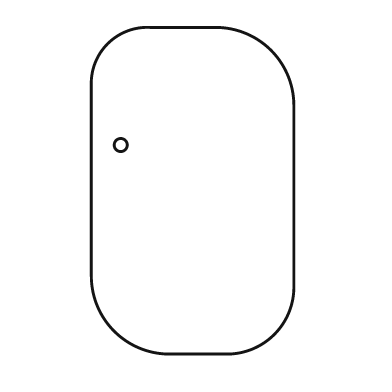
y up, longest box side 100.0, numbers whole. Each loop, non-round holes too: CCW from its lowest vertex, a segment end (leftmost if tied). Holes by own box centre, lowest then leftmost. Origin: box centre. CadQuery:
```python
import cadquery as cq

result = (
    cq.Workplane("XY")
    .moveTo(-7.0, -50.0)
    .lineTo(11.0, -50.0)
    .threePointArc((25.0, -44.0), (31.0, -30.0))
    .lineTo(31.0, 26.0)
    .threePointArc((24.0, 43.0), (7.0, 50.0))
    .lineTo(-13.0, 50.0)
    .threePointArc((-26.0, 45.0), (-31.0, 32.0))
    .lineTo(-31.0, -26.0)
    .threePointArc((-24.0, -43.0), (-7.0, -50.0))
    .close()
    .moveTo(-22.0, 14.0)
    .circle(2.0)
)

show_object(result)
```